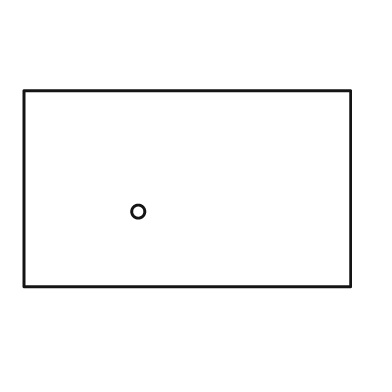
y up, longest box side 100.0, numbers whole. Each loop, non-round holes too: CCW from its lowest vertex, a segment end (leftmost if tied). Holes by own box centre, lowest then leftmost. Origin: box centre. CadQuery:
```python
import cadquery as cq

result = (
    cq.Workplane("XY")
    .moveTo(-50.0, -30.0)
    .lineTo(50.0, -30.0)
    .lineTo(50.0, 30.0)
    .lineTo(-50.0, 30.0)
    .close()
    .moveTo(-15.0, -7.0)
    .circle(2.0)
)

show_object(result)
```